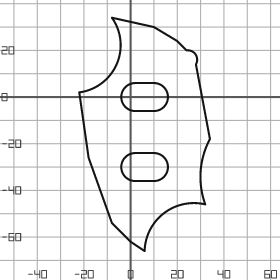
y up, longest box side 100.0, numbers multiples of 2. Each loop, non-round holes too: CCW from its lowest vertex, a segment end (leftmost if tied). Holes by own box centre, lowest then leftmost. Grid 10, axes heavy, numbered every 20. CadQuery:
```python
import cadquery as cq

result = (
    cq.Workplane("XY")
    .moveTo(6.0, -66.0)
    .threePointArc((14.0, -50.0), (32.0, -46.0))
    .threePointArc((30.0, -32.0), (34.0, -18.0))
    .lineTo(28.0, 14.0)
    .threePointArc((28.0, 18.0), (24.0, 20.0))
    .lineTo(20.0, 24.0)
    .lineTo(10.0, 30.0)
    .lineTo(-8.0, 34.0)
    .threePointArc((-6.0, 14.0), (-22.0, 2.0))
    .lineTo(-18.0, -26.0)
    .lineTo(-8.0, -54.0)
    .lineTo(0.0, -62.0)
    .close()
    .moveTo(2.0, -36.0)
    .lineTo(10.0, -36.0)
    .threePointArc((16.0, -30.0), (10.0, -24.0))
    .lineTo(2.0, -24.0)
    .threePointArc((-4.0, -30.0), (2.0, -36.0))
    .close()
    .moveTo(2.0, -6.0)
    .lineTo(10.0, -6.0)
    .threePointArc((16.0, 0.0), (10.0, 6.0))
    .lineTo(2.0, 6.0)
    .threePointArc((-4.0, 0.0), (2.0, -6.0))
    .close()
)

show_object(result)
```